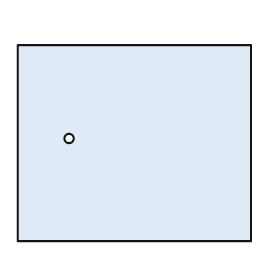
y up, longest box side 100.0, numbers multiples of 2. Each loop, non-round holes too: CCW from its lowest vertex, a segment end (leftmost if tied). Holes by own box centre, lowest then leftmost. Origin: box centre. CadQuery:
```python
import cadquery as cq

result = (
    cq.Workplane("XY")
    .moveTo(-50.0, -42.0)
    .lineTo(50.0, -42.0)
    .lineTo(50.0, 42.0)
    .lineTo(-50.0, 42.0)
    .close()
    .moveTo(-28.0, 2.0)
    .circle(2.0)
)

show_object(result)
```